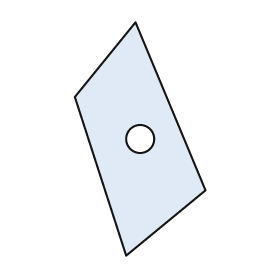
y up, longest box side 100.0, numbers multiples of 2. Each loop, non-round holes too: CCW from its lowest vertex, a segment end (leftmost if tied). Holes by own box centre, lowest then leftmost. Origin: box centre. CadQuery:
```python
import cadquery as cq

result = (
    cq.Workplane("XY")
    .moveTo(-6.0, -50.0)
    .lineTo(28.0, -22.0)
    .lineTo(-2.0, 50.0)
    .lineTo(-28.0, 18.0)
    .close()
    .moveTo(0.0, 0.0)
    .circle(6.0)
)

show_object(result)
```